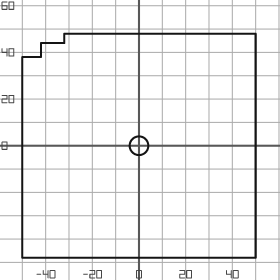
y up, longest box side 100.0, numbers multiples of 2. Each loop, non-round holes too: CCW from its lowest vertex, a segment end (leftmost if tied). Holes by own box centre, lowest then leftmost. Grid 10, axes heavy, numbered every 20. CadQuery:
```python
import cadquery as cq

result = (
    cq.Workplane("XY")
    .moveTo(-50.0, -48.0)
    .lineTo(50.0, -48.0)
    .lineTo(50.0, 48.0)
    .lineTo(-32.0, 48.0)
    .lineTo(-32.0, 44.0)
    .lineTo(-42.0, 44.0)
    .lineTo(-42.0, 38.0)
    .lineTo(-50.0, 38.0)
    .close()
    .moveTo(0.0, 0.0)
    .circle(4.0)
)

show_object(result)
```